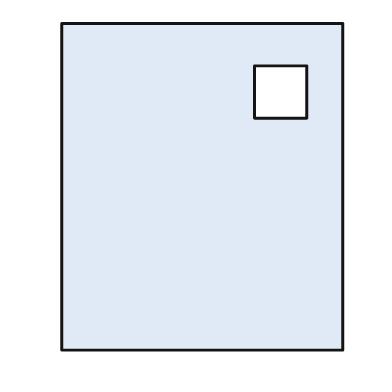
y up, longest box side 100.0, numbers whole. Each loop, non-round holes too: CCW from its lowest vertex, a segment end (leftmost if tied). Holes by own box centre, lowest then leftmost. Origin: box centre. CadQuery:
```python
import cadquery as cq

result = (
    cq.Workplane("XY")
    .moveTo(-43.0, -50.0)
    .lineTo(43.0, -50.0)
    .lineTo(43.0, 50.0)
    .lineTo(-43.0, 50.0)
    .close()
    .moveTo(16.0, 21.0)
    .lineTo(32.0, 21.0)
    .lineTo(32.0, 37.0)
    .lineTo(16.0, 37.0)
    .close()
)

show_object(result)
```